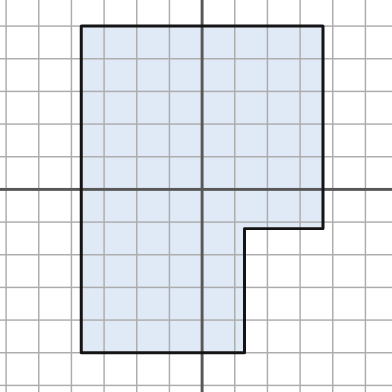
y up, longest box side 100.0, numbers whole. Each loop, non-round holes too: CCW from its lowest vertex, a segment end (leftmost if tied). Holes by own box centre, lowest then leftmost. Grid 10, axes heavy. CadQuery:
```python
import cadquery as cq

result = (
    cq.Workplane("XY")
    .moveTo(-37.0, -50.0)
    .lineTo(13.0, -50.0)
    .lineTo(13.0, -12.0)
    .lineTo(37.0, -12.0)
    .lineTo(37.0, 50.0)
    .lineTo(-37.0, 50.0)
    .close()
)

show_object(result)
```